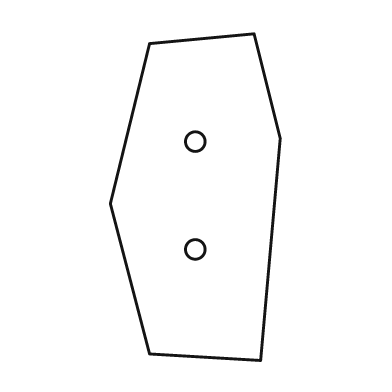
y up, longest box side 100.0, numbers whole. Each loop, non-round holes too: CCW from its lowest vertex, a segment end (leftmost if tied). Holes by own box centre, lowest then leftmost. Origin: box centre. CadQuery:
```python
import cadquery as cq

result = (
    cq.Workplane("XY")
    .moveTo(20.0, -50.0)
    .lineTo(26.0, 18.0)
    .lineTo(18.0, 50.0)
    .lineTo(-14.0, 47.0)
    .lineTo(-26.0, -2.0)
    .lineTo(-14.0, -48.0)
    .close()
    .moveTo(0.0, -16.0)
    .circle(3.0)
    .moveTo(0.0, 17.0)
    .circle(3.0)
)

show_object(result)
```